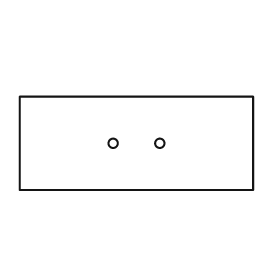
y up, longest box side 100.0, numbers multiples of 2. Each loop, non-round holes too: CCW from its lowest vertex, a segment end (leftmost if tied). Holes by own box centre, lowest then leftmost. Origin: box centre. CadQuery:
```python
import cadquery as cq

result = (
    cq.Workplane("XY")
    .moveTo(-50.0, -20.0)
    .lineTo(50.0, -20.0)
    .lineTo(50.0, 20.0)
    .lineTo(-50.0, 20.0)
    .close()
    .moveTo(-10.0, 0.0)
    .circle(2.0)
    .moveTo(10.0, 0.0)
    .circle(2.0)
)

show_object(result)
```